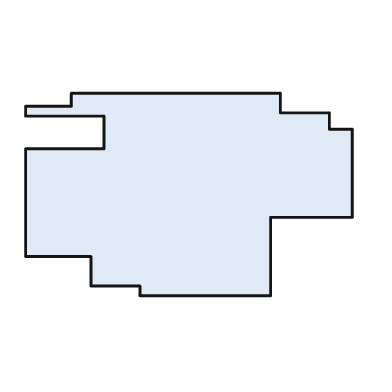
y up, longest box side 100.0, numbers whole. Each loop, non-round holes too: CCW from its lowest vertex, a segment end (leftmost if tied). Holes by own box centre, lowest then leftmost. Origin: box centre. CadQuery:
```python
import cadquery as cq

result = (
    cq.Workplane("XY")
    .moveTo(-15.0, -31.0)
    .lineTo(25.0, -31.0)
    .lineTo(25.0, -7.0)
    .lineTo(50.0, -7.0)
    .lineTo(50.0, 20.0)
    .lineTo(43.0, 20.0)
    .lineTo(43.0, 25.0)
    .lineTo(28.0, 25.0)
    .lineTo(28.0, 31.0)
    .lineTo(-36.0, 31.0)
    .lineTo(-36.0, 27.0)
    .lineTo(-50.0, 27.0)
    .lineTo(-50.0, 24.0)
    .lineTo(-26.0, 24.0)
    .lineTo(-26.0, 14.0)
    .lineTo(-50.0, 14.0)
    .lineTo(-50.0, -19.0)
    .lineTo(-30.0, -19.0)
    .lineTo(-30.0, -28.0)
    .lineTo(-15.0, -28.0)
    .close()
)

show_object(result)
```